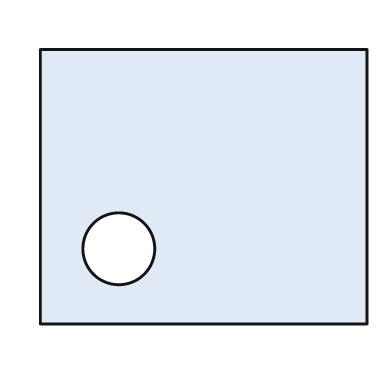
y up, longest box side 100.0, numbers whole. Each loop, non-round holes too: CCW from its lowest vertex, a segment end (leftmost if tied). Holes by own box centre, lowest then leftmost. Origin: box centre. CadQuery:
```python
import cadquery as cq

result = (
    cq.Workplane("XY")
    .moveTo(-50.0, -42.0)
    .lineTo(50.0, -42.0)
    .lineTo(50.0, 42.0)
    .lineTo(-50.0, 42.0)
    .close()
    .moveTo(-26.0, -19.0)
    .circle(11.0)
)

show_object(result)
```